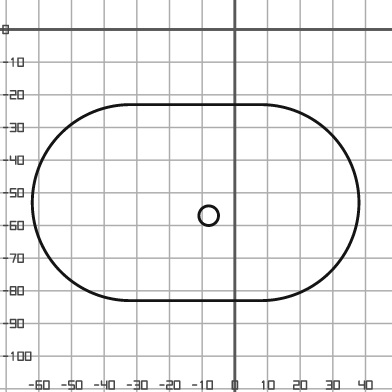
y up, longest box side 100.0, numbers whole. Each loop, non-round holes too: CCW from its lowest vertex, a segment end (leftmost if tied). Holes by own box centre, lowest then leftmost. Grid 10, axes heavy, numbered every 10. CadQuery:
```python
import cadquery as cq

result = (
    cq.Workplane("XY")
    .moveTo(-32.0, -83.0)
    .lineTo(8.0, -83.0)
    .threePointArc((38.0, -53.0), (8.0, -23.0))
    .lineTo(-32.0, -23.0)
    .threePointArc((-62.0, -53.0), (-32.0, -83.0))
    .close()
    .moveTo(-8.0, -57.0)
    .circle(3.0)
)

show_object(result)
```